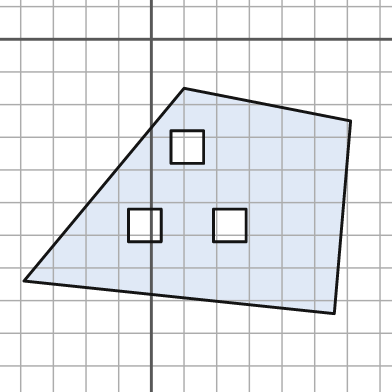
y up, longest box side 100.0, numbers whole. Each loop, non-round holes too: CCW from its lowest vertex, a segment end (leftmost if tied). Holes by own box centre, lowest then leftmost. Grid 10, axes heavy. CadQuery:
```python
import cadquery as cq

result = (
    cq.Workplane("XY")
    .moveTo(56.0, -84.0)
    .lineTo(61.0, -25.0)
    .lineTo(10.0, -15.0)
    .lineTo(-39.0, -74.0)
    .close()
    .moveTo(-7.0, -62.0)
    .lineTo(3.0, -62.0)
    .lineTo(3.0, -52.0)
    .lineTo(-7.0, -52.0)
    .close()
    .moveTo(19.0, -62.0)
    .lineTo(29.0, -62.0)
    .lineTo(29.0, -52.0)
    .lineTo(19.0, -52.0)
    .close()
    .moveTo(6.0, -38.0)
    .lineTo(16.0, -38.0)
    .lineTo(16.0, -28.0)
    .lineTo(6.0, -28.0)
    .close()
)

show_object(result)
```